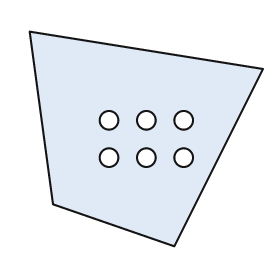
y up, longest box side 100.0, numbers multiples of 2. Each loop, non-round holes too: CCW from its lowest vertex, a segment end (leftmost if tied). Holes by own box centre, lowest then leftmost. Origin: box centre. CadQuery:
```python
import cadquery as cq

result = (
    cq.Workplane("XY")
    .moveTo(12.0, -46.0)
    .lineTo(50.0, 30.0)
    .lineTo(-50.0, 46.0)
    .lineTo(-40.0, -28.0)
    .close()
    .moveTo(-16.0, -8.0)
    .circle(4.0)
    .moveTo(0.0, -8.0)
    .circle(4.0)
    .moveTo(16.0, -8.0)
    .circle(4.0)
    .moveTo(-16.0, 8.0)
    .circle(4.0)
    .moveTo(0.0, 8.0)
    .circle(4.0)
    .moveTo(16.0, 8.0)
    .circle(4.0)
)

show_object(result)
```